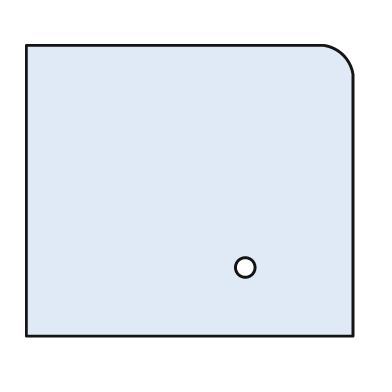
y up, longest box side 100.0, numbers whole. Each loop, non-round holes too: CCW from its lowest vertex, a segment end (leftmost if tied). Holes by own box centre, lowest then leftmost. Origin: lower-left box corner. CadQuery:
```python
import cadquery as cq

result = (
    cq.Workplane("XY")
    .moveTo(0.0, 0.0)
    .lineTo(100.0, 0.0)
    .lineTo(100.0, 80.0)
    .threePointArc((97.0, 86.0), (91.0, 89.0))
    .lineTo(0.0, 89.0)
    .close()
    .moveTo(67.0, 21.0)
    .circle(3.0)
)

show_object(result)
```